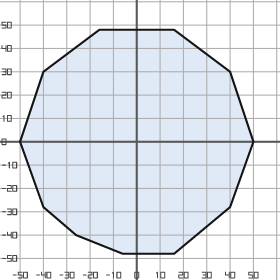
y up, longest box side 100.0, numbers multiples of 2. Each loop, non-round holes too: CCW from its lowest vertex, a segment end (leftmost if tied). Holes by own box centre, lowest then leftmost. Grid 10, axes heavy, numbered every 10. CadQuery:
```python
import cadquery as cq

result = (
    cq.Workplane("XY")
    .moveTo(-6.0, -48.0)
    .lineTo(16.0, -48.0)
    .lineTo(40.0, -28.0)
    .lineTo(50.0, 0.0)
    .lineTo(40.0, 30.0)
    .lineTo(16.0, 48.0)
    .lineTo(-16.0, 48.0)
    .lineTo(-40.0, 30.0)
    .lineTo(-50.0, 0.0)
    .lineTo(-40.0, -28.0)
    .lineTo(-26.0, -40.0)
    .close()
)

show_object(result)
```